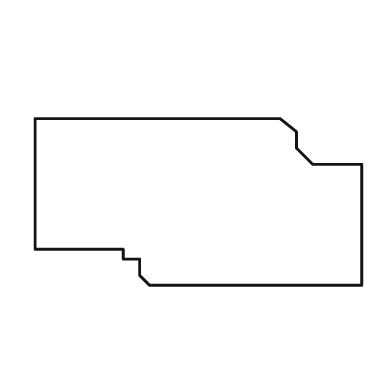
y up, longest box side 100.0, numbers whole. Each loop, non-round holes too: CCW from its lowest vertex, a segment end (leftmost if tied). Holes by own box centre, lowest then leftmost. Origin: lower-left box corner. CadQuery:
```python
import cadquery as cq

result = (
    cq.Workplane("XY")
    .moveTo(35.0, 0.0)
    .lineTo(100.0, 0.0)
    .lineTo(100.0, 37.0)
    .lineTo(85.0, 37.0)
    .lineTo(80.0, 42.0)
    .lineTo(80.0, 47.0)
    .lineTo(75.0, 51.0)
    .lineTo(0.0, 51.0)
    .lineTo(0.0, 11.0)
    .lineTo(27.0, 11.0)
    .lineTo(27.0, 8.0)
    .lineTo(32.0, 8.0)
    .lineTo(32.0, 3.0)
    .close()
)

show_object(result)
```